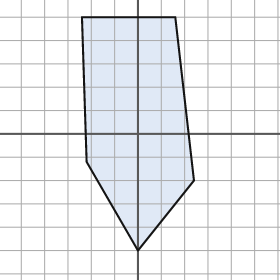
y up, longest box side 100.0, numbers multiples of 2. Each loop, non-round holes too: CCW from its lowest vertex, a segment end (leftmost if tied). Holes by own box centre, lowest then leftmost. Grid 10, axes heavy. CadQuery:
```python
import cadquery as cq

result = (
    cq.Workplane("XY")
    .moveTo(0.0, -50.0)
    .lineTo(24.0, -20.0)
    .lineTo(16.0, 50.0)
    .lineTo(-24.0, 50.0)
    .lineTo(-22.0, -12.0)
    .close()
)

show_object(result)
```